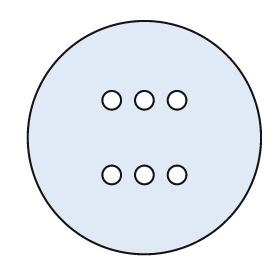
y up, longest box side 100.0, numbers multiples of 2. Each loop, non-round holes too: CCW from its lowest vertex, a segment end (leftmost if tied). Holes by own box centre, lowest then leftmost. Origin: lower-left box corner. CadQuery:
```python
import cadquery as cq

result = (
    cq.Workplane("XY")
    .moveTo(50.0, 50.0)
    .circle(50.0)
    .moveTo(36.0, 34.0)
    .circle(4.0)
    .moveTo(50.0, 34.0)
    .circle(4.0)
    .moveTo(64.0, 34.0)
    .circle(4.0)
    .moveTo(36.0, 66.0)
    .circle(4.0)
    .moveTo(50.0, 66.0)
    .circle(4.0)
    .moveTo(64.0, 66.0)
    .circle(4.0)
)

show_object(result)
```